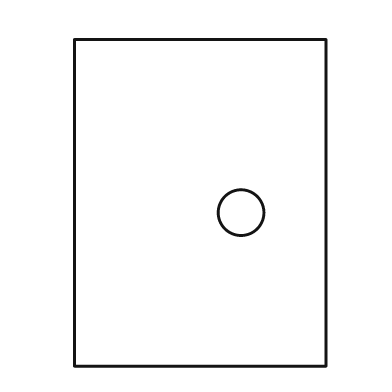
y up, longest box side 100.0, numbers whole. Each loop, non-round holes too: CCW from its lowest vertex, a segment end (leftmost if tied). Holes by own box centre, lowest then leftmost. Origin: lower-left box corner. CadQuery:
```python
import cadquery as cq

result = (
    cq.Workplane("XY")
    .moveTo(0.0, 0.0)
    .lineTo(77.0, 0.0)
    .lineTo(77.0, 100.0)
    .lineTo(0.0, 100.0)
    .close()
    .moveTo(51.0, 47.0)
    .circle(7.0)
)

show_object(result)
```